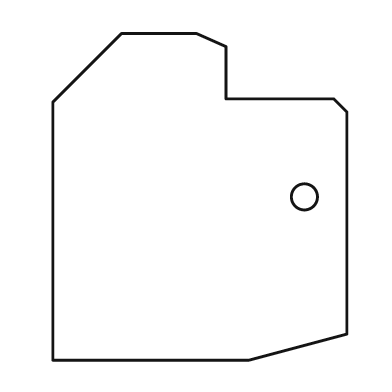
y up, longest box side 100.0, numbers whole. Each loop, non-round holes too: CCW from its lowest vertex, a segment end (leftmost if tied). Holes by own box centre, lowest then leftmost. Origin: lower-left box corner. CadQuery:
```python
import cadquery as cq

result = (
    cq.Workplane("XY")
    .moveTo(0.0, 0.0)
    .lineTo(60.0, 0.0)
    .lineTo(90.0, 8.0)
    .lineTo(90.0, 76.0)
    .lineTo(86.0, 80.0)
    .lineTo(53.0, 80.0)
    .lineTo(53.0, 96.0)
    .lineTo(44.0, 100.0)
    .lineTo(21.0, 100.0)
    .lineTo(0.0, 79.0)
    .close()
    .moveTo(77.0, 50.0)
    .circle(4.0)
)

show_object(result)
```